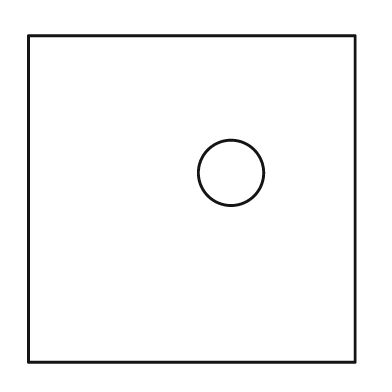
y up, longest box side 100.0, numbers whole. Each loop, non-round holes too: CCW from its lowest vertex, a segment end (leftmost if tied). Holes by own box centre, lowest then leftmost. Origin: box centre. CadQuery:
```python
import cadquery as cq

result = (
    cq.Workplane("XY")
    .moveTo(-50.0, -50.0)
    .lineTo(50.0, -50.0)
    .lineTo(50.0, 50.0)
    .lineTo(-50.0, 50.0)
    .close()
    .moveTo(12.0, 8.0)
    .circle(10.0)
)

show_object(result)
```